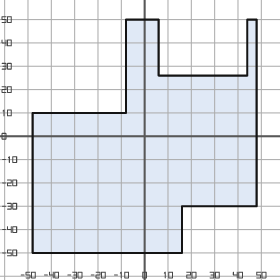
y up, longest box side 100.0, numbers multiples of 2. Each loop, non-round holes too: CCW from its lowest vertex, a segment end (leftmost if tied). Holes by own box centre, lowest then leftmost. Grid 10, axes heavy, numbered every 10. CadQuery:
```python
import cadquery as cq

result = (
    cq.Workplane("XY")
    .moveTo(-48.0, -50.0)
    .lineTo(16.0, -50.0)
    .lineTo(16.0, -30.0)
    .lineTo(48.0, -30.0)
    .lineTo(48.0, 50.0)
    .lineTo(44.0, 50.0)
    .lineTo(44.0, 26.0)
    .lineTo(6.0, 26.0)
    .lineTo(6.0, 50.0)
    .lineTo(-8.0, 50.0)
    .lineTo(-8.0, 10.0)
    .lineTo(-48.0, 10.0)
    .close()
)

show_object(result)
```